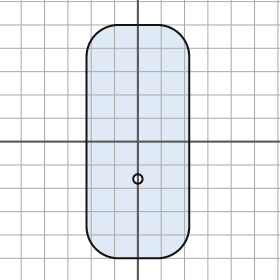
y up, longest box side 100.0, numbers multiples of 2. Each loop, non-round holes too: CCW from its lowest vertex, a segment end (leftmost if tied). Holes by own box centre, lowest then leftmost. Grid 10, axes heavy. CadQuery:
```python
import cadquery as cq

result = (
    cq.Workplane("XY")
    .moveTo(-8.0, -50.0)
    .lineTo(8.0, -50.0)
    .threePointArc((18.0, -46.0), (22.0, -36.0))
    .lineTo(22.0, 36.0)
    .threePointArc((18.0, 46.0), (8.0, 50.0))
    .lineTo(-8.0, 50.0)
    .threePointArc((-18.0, 46.0), (-22.0, 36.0))
    .lineTo(-22.0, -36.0)
    .threePointArc((-18.0, -46.0), (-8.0, -50.0))
    .close()
    .moveTo(0.0, -16.0)
    .circle(2.0)
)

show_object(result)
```